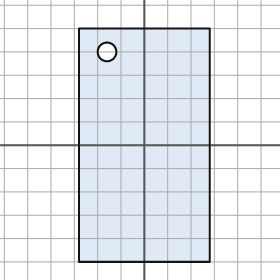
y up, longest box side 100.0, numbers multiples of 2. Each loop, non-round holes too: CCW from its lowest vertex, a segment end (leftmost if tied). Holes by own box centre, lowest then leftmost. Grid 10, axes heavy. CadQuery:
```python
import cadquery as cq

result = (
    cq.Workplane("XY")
    .moveTo(-28.0, -50.0)
    .lineTo(28.0, -50.0)
    .lineTo(28.0, 50.0)
    .lineTo(-28.0, 50.0)
    .close()
    .moveTo(-16.0, 40.0)
    .circle(4.0)
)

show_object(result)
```